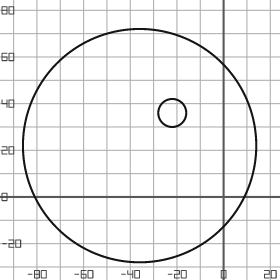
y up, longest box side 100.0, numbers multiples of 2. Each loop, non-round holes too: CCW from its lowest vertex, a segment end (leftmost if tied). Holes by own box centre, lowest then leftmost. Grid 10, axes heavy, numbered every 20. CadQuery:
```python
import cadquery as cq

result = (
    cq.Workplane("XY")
    .moveTo(-36.0, 22.0)
    .circle(50.0)
    .moveTo(-22.0, 36.0)
    .circle(6.0)
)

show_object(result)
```